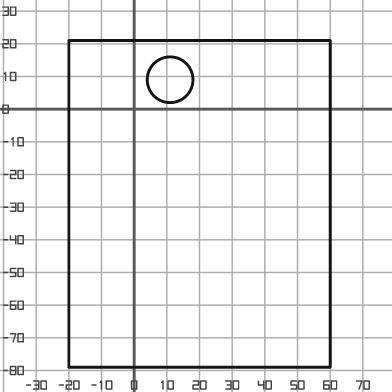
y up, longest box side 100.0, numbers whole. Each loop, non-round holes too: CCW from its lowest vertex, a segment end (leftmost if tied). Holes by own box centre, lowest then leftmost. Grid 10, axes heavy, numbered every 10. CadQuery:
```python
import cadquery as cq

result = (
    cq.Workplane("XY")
    .moveTo(-20.0, -79.0)
    .lineTo(60.0, -79.0)
    .lineTo(60.0, 21.0)
    .lineTo(-20.0, 21.0)
    .close()
    .moveTo(11.0, 9.0)
    .circle(7.0)
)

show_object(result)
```